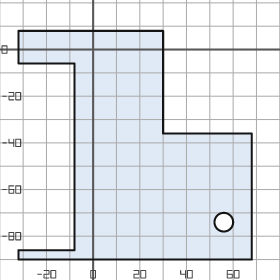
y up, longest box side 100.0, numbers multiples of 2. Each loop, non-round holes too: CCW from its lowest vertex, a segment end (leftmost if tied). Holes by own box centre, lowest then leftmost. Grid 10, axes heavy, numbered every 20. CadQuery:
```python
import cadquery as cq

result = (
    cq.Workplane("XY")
    .moveTo(-32.0, -90.0)
    .lineTo(68.0, -90.0)
    .lineTo(68.0, -36.0)
    .lineTo(30.0, -36.0)
    .lineTo(30.0, 8.0)
    .lineTo(-32.0, 8.0)
    .lineTo(-32.0, -6.0)
    .lineTo(-8.0, -6.0)
    .lineTo(-8.0, -86.0)
    .lineTo(-32.0, -86.0)
    .close()
    .moveTo(56.0, -74.0)
    .circle(4.0)
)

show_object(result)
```